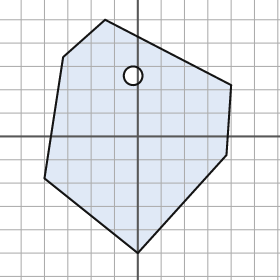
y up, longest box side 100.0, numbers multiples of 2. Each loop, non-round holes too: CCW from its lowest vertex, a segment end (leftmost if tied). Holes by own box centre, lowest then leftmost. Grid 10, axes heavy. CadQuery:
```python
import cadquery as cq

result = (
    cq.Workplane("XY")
    .moveTo(0.0, -50.0)
    .lineTo(38.0, -8.0)
    .lineTo(40.0, 22.0)
    .lineTo(-14.0, 50.0)
    .lineTo(-32.0, 34.0)
    .lineTo(-40.0, -18.0)
    .close()
    .moveTo(-2.0, 26.0)
    .circle(4.0)
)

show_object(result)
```